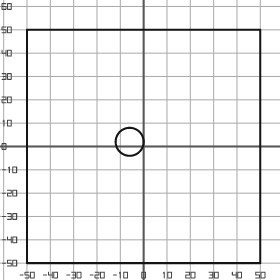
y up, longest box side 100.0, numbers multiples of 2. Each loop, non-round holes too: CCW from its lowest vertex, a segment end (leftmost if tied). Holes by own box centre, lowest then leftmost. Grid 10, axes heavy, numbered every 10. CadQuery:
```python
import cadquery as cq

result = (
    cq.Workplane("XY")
    .moveTo(-50.0, -50.0)
    .lineTo(50.0, -50.0)
    .lineTo(50.0, 50.0)
    .lineTo(-50.0, 50.0)
    .close()
    .moveTo(-6.0, 2.0)
    .circle(6.0)
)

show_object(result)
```